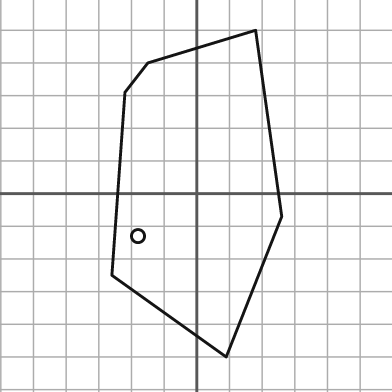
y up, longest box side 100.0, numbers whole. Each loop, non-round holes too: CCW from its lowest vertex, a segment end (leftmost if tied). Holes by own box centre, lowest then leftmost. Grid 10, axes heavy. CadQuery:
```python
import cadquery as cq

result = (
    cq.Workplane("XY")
    .moveTo(9.0, -50.0)
    .lineTo(26.0, -7.0)
    .lineTo(18.0, 50.0)
    .lineTo(-15.0, 40.0)
    .lineTo(-22.0, 31.0)
    .lineTo(-26.0, -25.0)
    .close()
    .moveTo(-18.0, -13.0)
    .circle(2.0)
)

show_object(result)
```